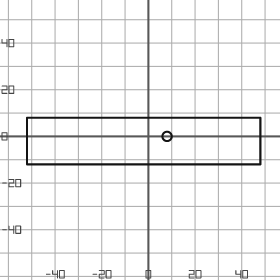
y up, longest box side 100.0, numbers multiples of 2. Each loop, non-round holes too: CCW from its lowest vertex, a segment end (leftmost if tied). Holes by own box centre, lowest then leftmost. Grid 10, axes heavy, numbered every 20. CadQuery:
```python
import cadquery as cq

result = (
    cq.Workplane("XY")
    .moveTo(-52.0, -12.0)
    .lineTo(48.0, -12.0)
    .lineTo(48.0, 8.0)
    .lineTo(-52.0, 8.0)
    .close()
    .moveTo(8.0, 0.0)
    .circle(2.0)
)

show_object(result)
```